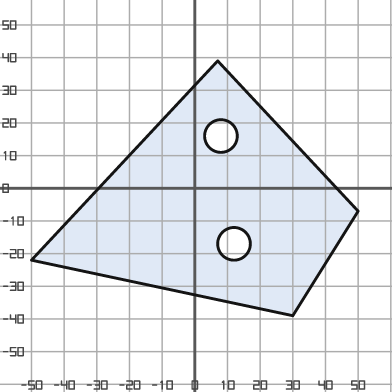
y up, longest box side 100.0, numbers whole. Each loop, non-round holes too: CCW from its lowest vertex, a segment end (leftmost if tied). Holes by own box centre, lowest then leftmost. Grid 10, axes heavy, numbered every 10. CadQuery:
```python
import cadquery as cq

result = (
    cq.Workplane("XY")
    .moveTo(30.0, -39.0)
    .lineTo(50.0, -7.0)
    .lineTo(7.0, 39.0)
    .lineTo(-50.0, -22.0)
    .close()
    .moveTo(12.0, -17.0)
    .circle(5.0)
    .moveTo(8.0, 16.0)
    .circle(5.0)
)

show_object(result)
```